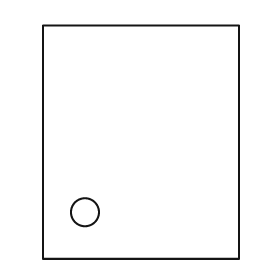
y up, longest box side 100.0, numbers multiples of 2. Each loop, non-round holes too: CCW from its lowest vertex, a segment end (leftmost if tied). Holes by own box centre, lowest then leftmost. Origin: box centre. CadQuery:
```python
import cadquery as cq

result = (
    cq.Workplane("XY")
    .moveTo(-42.0, -50.0)
    .lineTo(42.0, -50.0)
    .lineTo(42.0, 50.0)
    .lineTo(-42.0, 50.0)
    .close()
    .moveTo(-24.0, -30.0)
    .circle(6.0)
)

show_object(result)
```